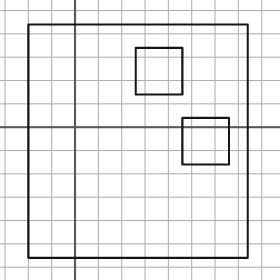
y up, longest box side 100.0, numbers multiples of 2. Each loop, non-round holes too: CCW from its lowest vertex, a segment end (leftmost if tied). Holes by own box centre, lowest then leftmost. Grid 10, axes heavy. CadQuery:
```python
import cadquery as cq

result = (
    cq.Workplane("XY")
    .moveTo(-20.0, -56.0)
    .lineTo(74.0, -56.0)
    .lineTo(74.0, 44.0)
    .lineTo(-20.0, 44.0)
    .close()
    .moveTo(46.0, -16.0)
    .lineTo(66.0, -16.0)
    .lineTo(66.0, 4.0)
    .lineTo(46.0, 4.0)
    .close()
    .moveTo(26.0, 14.0)
    .lineTo(46.0, 14.0)
    .lineTo(46.0, 34.0)
    .lineTo(26.0, 34.0)
    .close()
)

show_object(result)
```